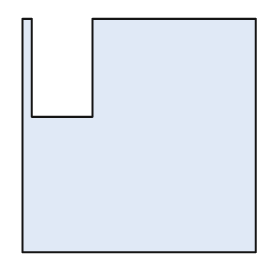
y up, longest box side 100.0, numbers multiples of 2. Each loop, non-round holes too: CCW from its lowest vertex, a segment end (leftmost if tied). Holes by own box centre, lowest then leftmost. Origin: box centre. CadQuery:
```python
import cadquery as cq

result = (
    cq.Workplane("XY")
    .moveTo(-50.0, -50.0)
    .lineTo(50.0, -50.0)
    .lineTo(50.0, 50.0)
    .lineTo(-20.0, 50.0)
    .lineTo(-20.0, 8.0)
    .lineTo(-46.0, 8.0)
    .lineTo(-46.0, 50.0)
    .lineTo(-50.0, 50.0)
    .close()
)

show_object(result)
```